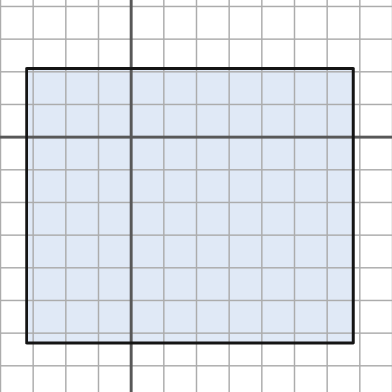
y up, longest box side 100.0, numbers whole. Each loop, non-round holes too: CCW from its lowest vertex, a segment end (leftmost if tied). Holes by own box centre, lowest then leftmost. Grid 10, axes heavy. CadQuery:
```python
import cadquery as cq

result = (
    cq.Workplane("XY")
    .moveTo(-32.0, -63.0)
    .lineTo(68.0, -63.0)
    .lineTo(68.0, 21.0)
    .lineTo(-32.0, 21.0)
    .close()
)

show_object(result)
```